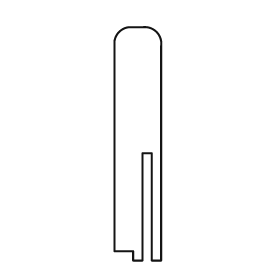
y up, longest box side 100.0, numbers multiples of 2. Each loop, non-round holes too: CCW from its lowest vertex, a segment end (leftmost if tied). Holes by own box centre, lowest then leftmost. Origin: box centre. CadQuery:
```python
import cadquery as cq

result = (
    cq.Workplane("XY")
    .moveTo(-2.0, -50.0)
    .lineTo(2.0, -50.0)
    .lineTo(2.0, -4.0)
    .lineTo(6.0, -4.0)
    .lineTo(6.0, -50.0)
    .lineTo(10.0, -50.0)
    .lineTo(10.0, 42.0)
    .threePointArc((8.0, 48.0), (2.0, 50.0))
    .lineTo(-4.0, 50.0)
    .threePointArc((-8.0, 48.0), (-10.0, 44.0))
    .lineTo(-10.0, -46.0)
    .lineTo(-2.0, -46.0)
    .close()
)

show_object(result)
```